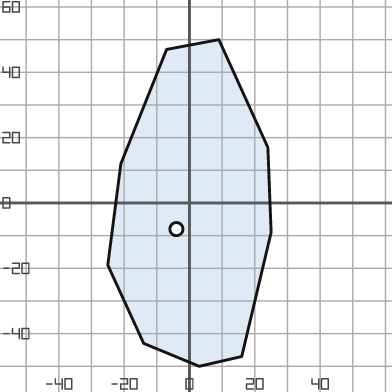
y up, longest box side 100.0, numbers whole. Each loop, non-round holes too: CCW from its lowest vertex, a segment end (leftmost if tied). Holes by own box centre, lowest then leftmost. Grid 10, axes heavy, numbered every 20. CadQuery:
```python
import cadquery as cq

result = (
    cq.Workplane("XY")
    .moveTo(3.0, -50.0)
    .lineTo(16.0, -47.0)
    .lineTo(25.0, -9.0)
    .lineTo(24.0, 17.0)
    .lineTo(9.0, 50.0)
    .lineTo(-7.0, 47.0)
    .lineTo(-21.0, 12.0)
    .lineTo(-25.0, -19.0)
    .lineTo(-14.0, -43.0)
    .close()
    .moveTo(-4.0, -8.0)
    .circle(2.0)
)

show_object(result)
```